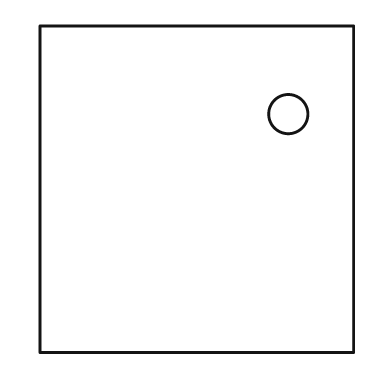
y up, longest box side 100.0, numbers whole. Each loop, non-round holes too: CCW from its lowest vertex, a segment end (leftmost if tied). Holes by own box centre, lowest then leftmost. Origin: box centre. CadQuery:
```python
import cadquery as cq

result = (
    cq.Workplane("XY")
    .moveTo(-48.0, -50.0)
    .lineTo(48.0, -50.0)
    .lineTo(48.0, 50.0)
    .lineTo(-48.0, 50.0)
    .close()
    .moveTo(28.0, 23.0)
    .circle(6.0)
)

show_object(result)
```